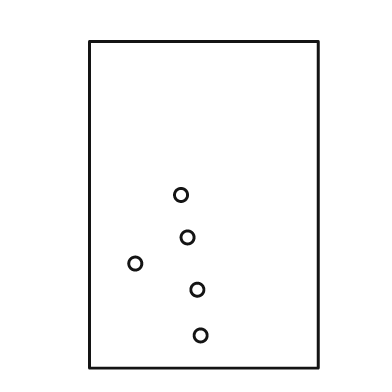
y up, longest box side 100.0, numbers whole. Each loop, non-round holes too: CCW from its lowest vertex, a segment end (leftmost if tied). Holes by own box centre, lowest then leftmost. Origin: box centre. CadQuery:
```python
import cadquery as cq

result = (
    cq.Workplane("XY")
    .moveTo(-35.0, -50.0)
    .lineTo(35.0, -50.0)
    .lineTo(35.0, 50.0)
    .lineTo(-35.0, 50.0)
    .close()
    .moveTo(-1.0, -40.0)
    .circle(2.0)
    .moveTo(-2.0, -26.0)
    .circle(2.0)
    .moveTo(-21.0, -18.0)
    .circle(2.0)
    .moveTo(-5.0, -10.0)
    .circle(2.0)
    .moveTo(-7.0, 3.0)
    .circle(2.0)
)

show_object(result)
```